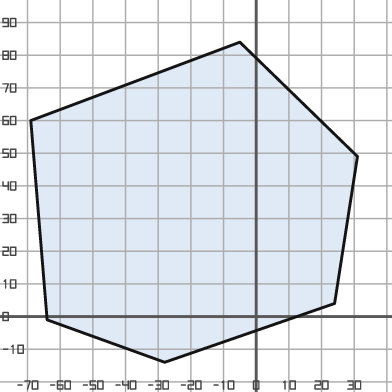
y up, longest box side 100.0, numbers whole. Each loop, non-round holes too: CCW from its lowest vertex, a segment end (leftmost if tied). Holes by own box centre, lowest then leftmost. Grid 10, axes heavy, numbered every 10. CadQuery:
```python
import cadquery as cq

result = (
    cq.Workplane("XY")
    .moveTo(-28.0, -14.0)
    .lineTo(24.0, 4.0)
    .lineTo(31.0, 49.0)
    .lineTo(-5.0, 84.0)
    .lineTo(-69.0, 60.0)
    .lineTo(-64.0, -1.0)
    .close()
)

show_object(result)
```